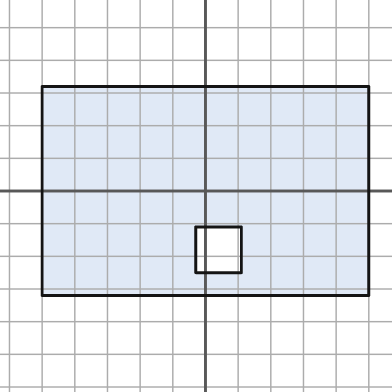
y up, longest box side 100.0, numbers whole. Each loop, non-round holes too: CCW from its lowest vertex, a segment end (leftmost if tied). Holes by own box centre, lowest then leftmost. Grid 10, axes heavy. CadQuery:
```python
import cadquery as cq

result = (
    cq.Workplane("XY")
    .moveTo(-50.0, -32.0)
    .lineTo(50.0, -32.0)
    .lineTo(50.0, 32.0)
    .lineTo(-50.0, 32.0)
    .close()
    .moveTo(-3.0, -25.0)
    .lineTo(11.0, -25.0)
    .lineTo(11.0, -11.0)
    .lineTo(-3.0, -11.0)
    .close()
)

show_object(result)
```